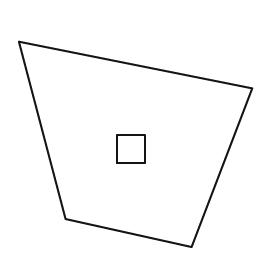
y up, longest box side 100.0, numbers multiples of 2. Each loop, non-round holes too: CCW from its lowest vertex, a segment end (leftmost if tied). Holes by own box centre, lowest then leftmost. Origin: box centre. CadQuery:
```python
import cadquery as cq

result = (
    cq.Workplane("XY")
    .moveTo(24.0, -44.0)
    .lineTo(50.0, 24.0)
    .lineTo(-50.0, 44.0)
    .lineTo(-30.0, -32.0)
    .close()
    .moveTo(-8.0, -8.0)
    .lineTo(4.0, -8.0)
    .lineTo(4.0, 4.0)
    .lineTo(-8.0, 4.0)
    .close()
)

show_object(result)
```